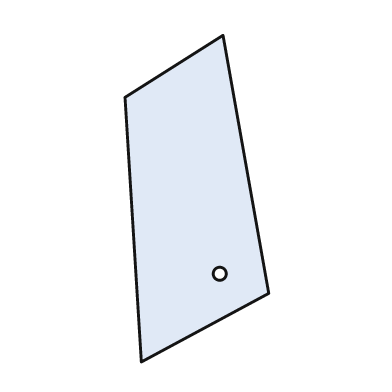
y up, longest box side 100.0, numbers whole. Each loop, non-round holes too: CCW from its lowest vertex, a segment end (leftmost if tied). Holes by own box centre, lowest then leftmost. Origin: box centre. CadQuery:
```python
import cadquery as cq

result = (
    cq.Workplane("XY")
    .moveTo(-17.0, -50.0)
    .lineTo(22.0, -29.0)
    .lineTo(8.0, 50.0)
    .lineTo(-22.0, 31.0)
    .close()
    .moveTo(7.0, -23.0)
    .circle(2.0)
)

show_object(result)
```